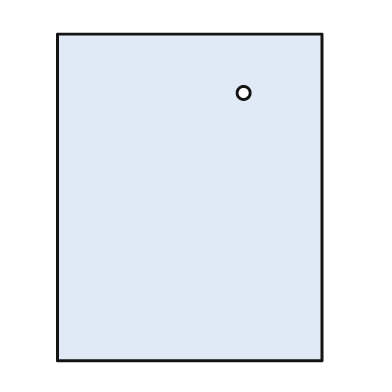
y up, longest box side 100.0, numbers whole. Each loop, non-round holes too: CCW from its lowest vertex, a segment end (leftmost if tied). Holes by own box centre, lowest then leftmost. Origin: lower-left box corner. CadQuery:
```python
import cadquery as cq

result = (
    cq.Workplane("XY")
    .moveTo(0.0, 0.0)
    .lineTo(81.0, 0.0)
    .lineTo(81.0, 100.0)
    .lineTo(0.0, 100.0)
    .close()
    .moveTo(57.0, 82.0)
    .circle(2.0)
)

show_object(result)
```